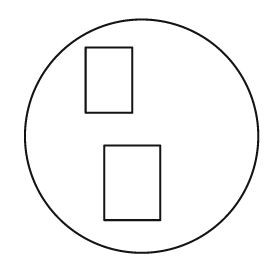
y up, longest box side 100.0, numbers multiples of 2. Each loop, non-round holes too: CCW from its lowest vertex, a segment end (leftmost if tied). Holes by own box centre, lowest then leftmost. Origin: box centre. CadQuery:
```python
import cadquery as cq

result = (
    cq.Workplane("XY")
    .moveTo(0.0, 0.0)
    .circle(50.0)
    .moveTo(-16.0, -36.0)
    .lineTo(8.0, -36.0)
    .lineTo(8.0, -4.0)
    .lineTo(-16.0, -4.0)
    .close()
    .moveTo(-24.0, 10.0)
    .lineTo(-4.0, 10.0)
    .lineTo(-4.0, 38.0)
    .lineTo(-24.0, 38.0)
    .close()
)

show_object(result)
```